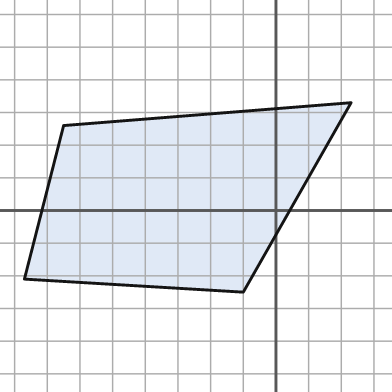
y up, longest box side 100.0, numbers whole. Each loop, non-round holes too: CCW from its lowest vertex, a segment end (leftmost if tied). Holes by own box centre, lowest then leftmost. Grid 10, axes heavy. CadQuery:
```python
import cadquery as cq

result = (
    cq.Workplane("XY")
    .moveTo(-10.0, -25.0)
    .lineTo(23.0, 33.0)
    .lineTo(-65.0, 26.0)
    .lineTo(-77.0, -21.0)
    .close()
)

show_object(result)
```